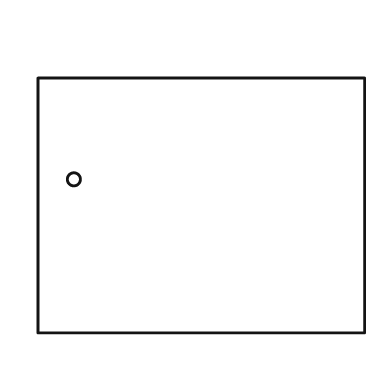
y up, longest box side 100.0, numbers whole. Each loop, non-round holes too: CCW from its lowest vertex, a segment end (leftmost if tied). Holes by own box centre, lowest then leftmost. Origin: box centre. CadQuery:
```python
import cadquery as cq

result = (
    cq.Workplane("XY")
    .moveTo(-50.0, -39.0)
    .lineTo(50.0, -39.0)
    .lineTo(50.0, 39.0)
    .lineTo(-50.0, 39.0)
    .close()
    .moveTo(-39.0, 8.0)
    .circle(2.0)
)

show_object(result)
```